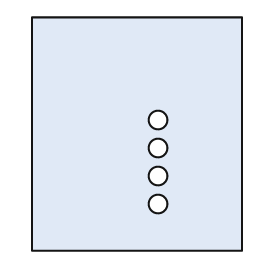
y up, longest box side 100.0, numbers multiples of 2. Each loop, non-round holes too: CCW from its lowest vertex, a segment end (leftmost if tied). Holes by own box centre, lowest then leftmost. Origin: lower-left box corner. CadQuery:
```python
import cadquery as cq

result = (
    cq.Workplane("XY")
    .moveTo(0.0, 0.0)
    .lineTo(90.0, 0.0)
    .lineTo(90.0, 100.0)
    .lineTo(0.0, 100.0)
    .close()
    .moveTo(54.0, 20.0)
    .circle(4.0)
    .moveTo(54.0, 32.0)
    .circle(4.0)
    .moveTo(54.0, 44.0)
    .circle(4.0)
    .moveTo(54.0, 56.0)
    .circle(4.0)
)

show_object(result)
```